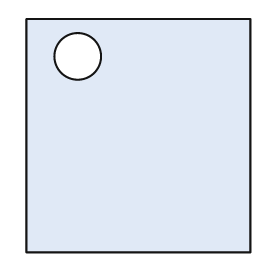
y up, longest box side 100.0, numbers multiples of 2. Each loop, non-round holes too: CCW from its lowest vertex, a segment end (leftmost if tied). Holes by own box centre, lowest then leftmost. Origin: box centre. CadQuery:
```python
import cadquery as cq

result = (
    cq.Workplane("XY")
    .moveTo(-48.0, -50.0)
    .lineTo(48.0, -50.0)
    .lineTo(48.0, 50.0)
    .lineTo(-48.0, 50.0)
    .close()
    .moveTo(-26.0, 34.0)
    .circle(10.0)
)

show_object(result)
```